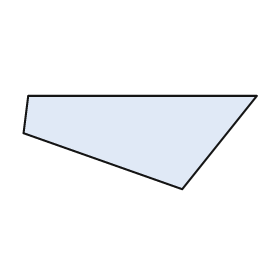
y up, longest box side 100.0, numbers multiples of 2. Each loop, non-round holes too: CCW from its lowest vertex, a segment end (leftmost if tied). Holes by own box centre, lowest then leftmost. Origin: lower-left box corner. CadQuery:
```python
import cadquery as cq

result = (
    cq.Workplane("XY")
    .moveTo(68.0, 0.0)
    .lineTo(100.0, 40.0)
    .lineTo(2.0, 40.0)
    .lineTo(0.0, 24.0)
    .close()
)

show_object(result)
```